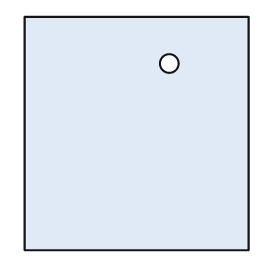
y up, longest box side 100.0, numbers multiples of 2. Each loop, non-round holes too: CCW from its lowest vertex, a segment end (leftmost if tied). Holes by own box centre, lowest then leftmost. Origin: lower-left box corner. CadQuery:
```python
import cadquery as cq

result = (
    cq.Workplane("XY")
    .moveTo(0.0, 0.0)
    .lineTo(96.0, 0.0)
    .lineTo(96.0, 100.0)
    .lineTo(0.0, 100.0)
    .close()
    .moveTo(62.0, 80.0)
    .circle(4.0)
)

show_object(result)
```